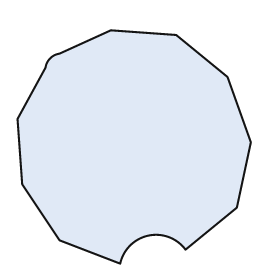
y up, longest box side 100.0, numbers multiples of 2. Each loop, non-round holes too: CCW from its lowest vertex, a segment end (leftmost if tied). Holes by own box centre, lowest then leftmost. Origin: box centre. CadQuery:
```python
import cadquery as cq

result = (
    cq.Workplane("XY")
    .moveTo(-6.0, -50.0)
    .threePointArc((6.0, -38.0), (22.0, -44.0))
    .lineTo(44.0, -26.0)
    .lineTo(50.0, 2.0)
    .lineTo(40.0, 30.0)
    .lineTo(18.0, 48.0)
    .lineTo(-10.0, 50.0)
    .lineTo(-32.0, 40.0)
    .threePointArc((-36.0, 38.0), (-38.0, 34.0))
    .lineTo(-50.0, 12.0)
    .lineTo(-48.0, -16.0)
    .lineTo(-32.0, -40.0)
    .close()
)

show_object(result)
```